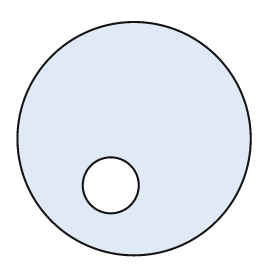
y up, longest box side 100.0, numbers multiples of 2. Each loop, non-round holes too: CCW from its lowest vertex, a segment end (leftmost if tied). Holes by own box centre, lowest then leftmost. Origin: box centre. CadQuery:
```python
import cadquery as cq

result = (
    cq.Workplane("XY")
    .moveTo(0.0, 0.0)
    .circle(50.0)
    .moveTo(-10.0, -20.0)
    .circle(12.0)
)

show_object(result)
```